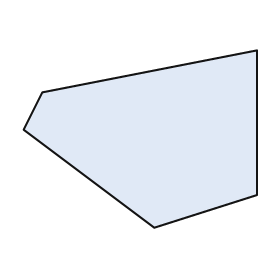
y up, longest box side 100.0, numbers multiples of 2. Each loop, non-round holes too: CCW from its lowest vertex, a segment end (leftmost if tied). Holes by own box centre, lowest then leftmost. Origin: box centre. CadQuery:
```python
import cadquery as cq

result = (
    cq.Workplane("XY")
    .moveTo(6.0, -38.0)
    .lineTo(50.0, -24.0)
    .lineTo(50.0, 38.0)
    .lineTo(-42.0, 20.0)
    .lineTo(-50.0, 4.0)
    .close()
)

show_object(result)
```